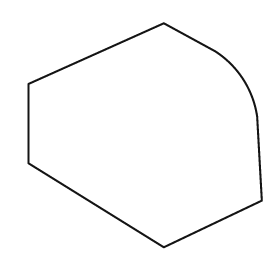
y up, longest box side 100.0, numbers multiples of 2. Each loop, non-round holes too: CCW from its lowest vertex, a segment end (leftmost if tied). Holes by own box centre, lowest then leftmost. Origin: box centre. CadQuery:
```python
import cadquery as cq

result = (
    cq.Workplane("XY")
    .moveTo(8.0, -48.0)
    .lineTo(50.0, -28.0)
    .lineTo(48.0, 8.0)
    .threePointArc((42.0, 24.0), (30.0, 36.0))
    .lineTo(8.0, 48.0)
    .lineTo(-50.0, 22.0)
    .lineTo(-50.0, -12.0)
    .close()
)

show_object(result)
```